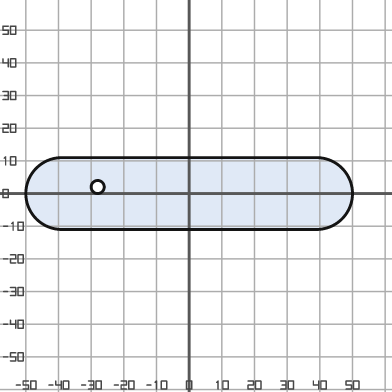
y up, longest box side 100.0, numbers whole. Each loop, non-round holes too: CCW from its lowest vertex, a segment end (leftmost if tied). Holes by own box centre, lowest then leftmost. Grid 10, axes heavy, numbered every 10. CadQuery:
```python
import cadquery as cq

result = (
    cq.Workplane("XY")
    .moveTo(-39.0, -11.0)
    .lineTo(39.0, -11.0)
    .threePointArc((50.0, 0.0), (39.0, 11.0))
    .lineTo(-39.0, 11.0)
    .threePointArc((-50.0, 0.0), (-39.0, -11.0))
    .close()
    .moveTo(-28.0, 2.0)
    .circle(2.0)
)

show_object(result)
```